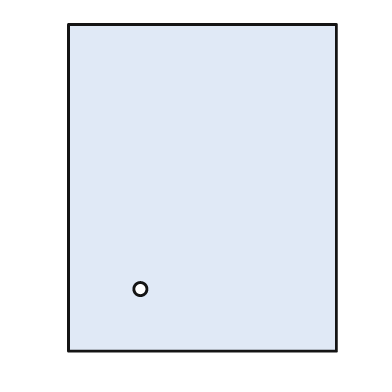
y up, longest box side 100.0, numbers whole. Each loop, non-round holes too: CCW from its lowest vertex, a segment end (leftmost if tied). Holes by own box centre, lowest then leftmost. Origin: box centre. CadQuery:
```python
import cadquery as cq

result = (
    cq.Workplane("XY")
    .moveTo(-41.0, -50.0)
    .lineTo(41.0, -50.0)
    .lineTo(41.0, 50.0)
    .lineTo(-41.0, 50.0)
    .close()
    .moveTo(-19.0, -31.0)
    .circle(2.0)
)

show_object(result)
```